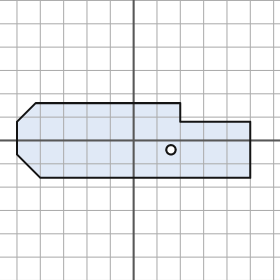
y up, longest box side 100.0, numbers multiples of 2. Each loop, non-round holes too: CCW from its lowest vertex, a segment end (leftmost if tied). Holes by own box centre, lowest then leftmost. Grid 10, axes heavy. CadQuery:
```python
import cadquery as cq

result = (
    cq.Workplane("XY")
    .moveTo(-40.0, -16.0)
    .lineTo(50.0, -16.0)
    .lineTo(50.0, 8.0)
    .lineTo(20.0, 8.0)
    .lineTo(20.0, 16.0)
    .lineTo(-42.0, 16.0)
    .lineTo(-50.0, 8.0)
    .lineTo(-50.0, -6.0)
    .close()
    .moveTo(16.0, -4.0)
    .circle(2.0)
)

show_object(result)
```